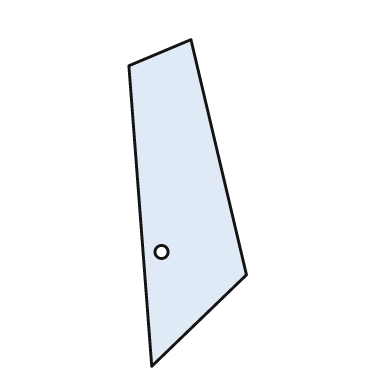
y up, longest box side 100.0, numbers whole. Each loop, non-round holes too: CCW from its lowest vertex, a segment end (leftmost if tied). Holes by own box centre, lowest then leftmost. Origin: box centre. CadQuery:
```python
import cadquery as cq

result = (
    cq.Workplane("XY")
    .moveTo(-11.0, -50.0)
    .lineTo(18.0, -22.0)
    .lineTo(1.0, 50.0)
    .lineTo(-18.0, 42.0)
    .close()
    .moveTo(-8.0, -15.0)
    .circle(2.0)
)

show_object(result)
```